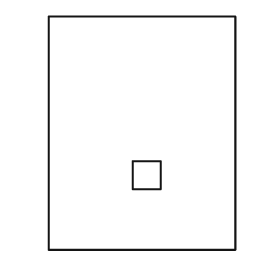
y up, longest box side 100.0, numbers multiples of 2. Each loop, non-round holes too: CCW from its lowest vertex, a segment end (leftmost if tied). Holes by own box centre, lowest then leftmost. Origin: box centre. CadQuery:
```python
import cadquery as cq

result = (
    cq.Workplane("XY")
    .moveTo(-40.0, -50.0)
    .lineTo(40.0, -50.0)
    .lineTo(40.0, 50.0)
    .lineTo(-40.0, 50.0)
    .close()
    .moveTo(-4.0, -24.0)
    .lineTo(8.0, -24.0)
    .lineTo(8.0, -12.0)
    .lineTo(-4.0, -12.0)
    .close()
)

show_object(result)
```